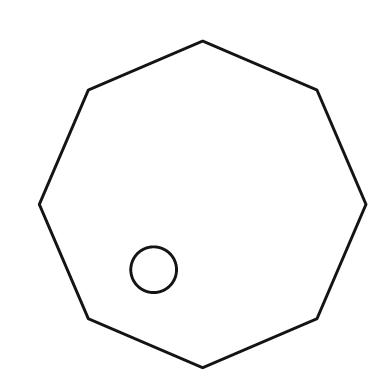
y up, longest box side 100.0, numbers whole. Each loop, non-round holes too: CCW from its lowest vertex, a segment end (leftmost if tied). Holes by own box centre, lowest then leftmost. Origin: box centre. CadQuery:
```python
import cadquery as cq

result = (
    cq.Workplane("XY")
    .moveTo(0.0, -50.0)
    .lineTo(35.0, -35.0)
    .lineTo(50.0, 0.0)
    .lineTo(35.0, 35.0)
    .lineTo(0.0, 50.0)
    .lineTo(-35.0, 35.0)
    .lineTo(-50.0, 0.0)
    .lineTo(-35.0, -35.0)
    .close()
    .moveTo(-15.0, -20.0)
    .circle(7.0)
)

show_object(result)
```